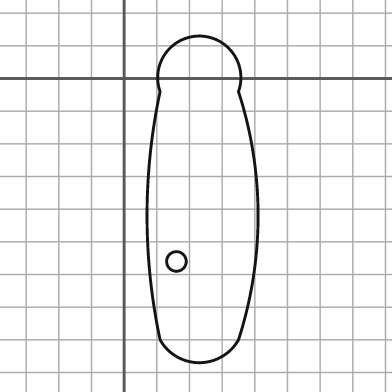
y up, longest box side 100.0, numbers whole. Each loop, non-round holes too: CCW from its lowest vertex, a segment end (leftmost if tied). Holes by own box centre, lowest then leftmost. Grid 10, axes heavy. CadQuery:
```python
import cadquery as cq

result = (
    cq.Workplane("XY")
    .moveTo(11.0, -80.0)
    .threePointArc((23.0, -87.0), (35.0, -80.0))
    .threePointArc((41.0, -42.0), (35.0, -4.0))
    .threePointArc((23.0, 13.0), (11.0, -4.0))
    .threePointArc((7.0, -42.0), (11.0, -80.0))
    .close()
    .moveTo(16.0, -56.0)
    .circle(3.0)
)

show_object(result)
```